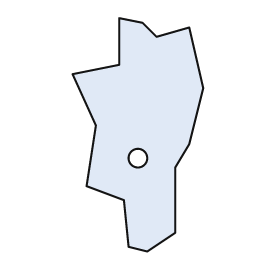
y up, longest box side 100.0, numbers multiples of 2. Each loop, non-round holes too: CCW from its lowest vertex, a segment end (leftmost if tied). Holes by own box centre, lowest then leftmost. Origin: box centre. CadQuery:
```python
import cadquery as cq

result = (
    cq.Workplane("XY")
    .moveTo(4.0, -50.0)
    .lineTo(16.0, -42.0)
    .lineTo(16.0, -14.0)
    .lineTo(22.0, -4.0)
    .lineTo(28.0, 20.0)
    .lineTo(22.0, 46.0)
    .lineTo(8.0, 42.0)
    .lineTo(2.0, 48.0)
    .lineTo(-8.0, 50.0)
    .lineTo(-8.0, 30.0)
    .lineTo(-28.0, 26.0)
    .lineTo(-18.0, 4.0)
    .lineTo(-22.0, -22.0)
    .lineTo(-6.0, -28.0)
    .lineTo(-4.0, -48.0)
    .close()
    .moveTo(0.0, -10.0)
    .circle(4.0)
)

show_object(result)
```